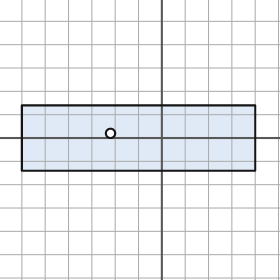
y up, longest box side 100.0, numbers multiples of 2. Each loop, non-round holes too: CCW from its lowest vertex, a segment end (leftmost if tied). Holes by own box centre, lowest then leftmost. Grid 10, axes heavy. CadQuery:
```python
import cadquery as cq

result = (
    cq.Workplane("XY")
    .moveTo(-60.0, -14.0)
    .lineTo(40.0, -14.0)
    .lineTo(40.0, 14.0)
    .lineTo(-60.0, 14.0)
    .close()
    .moveTo(-22.0, 2.0)
    .circle(2.0)
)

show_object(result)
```